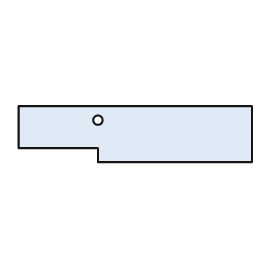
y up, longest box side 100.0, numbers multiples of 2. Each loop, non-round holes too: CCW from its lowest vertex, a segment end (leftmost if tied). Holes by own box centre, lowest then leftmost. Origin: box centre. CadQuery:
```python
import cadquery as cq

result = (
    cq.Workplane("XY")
    .moveTo(-16.0, -12.0)
    .lineTo(50.0, -12.0)
    .lineTo(50.0, 12.0)
    .lineTo(-50.0, 12.0)
    .lineTo(-50.0, -6.0)
    .lineTo(-16.0, -6.0)
    .close()
    .moveTo(-16.0, 6.0)
    .circle(2.0)
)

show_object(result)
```